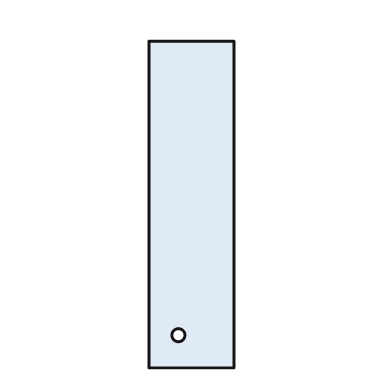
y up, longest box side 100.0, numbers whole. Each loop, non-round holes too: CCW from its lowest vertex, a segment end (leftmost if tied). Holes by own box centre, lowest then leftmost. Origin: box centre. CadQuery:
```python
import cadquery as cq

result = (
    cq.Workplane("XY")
    .moveTo(-13.0, -50.0)
    .lineTo(13.0, -50.0)
    .lineTo(13.0, 50.0)
    .lineTo(-13.0, 50.0)
    .close()
    .moveTo(-4.0, -40.0)
    .circle(2.0)
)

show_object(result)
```